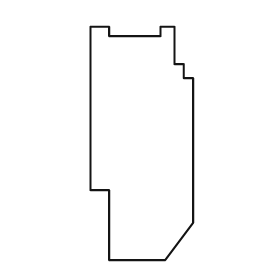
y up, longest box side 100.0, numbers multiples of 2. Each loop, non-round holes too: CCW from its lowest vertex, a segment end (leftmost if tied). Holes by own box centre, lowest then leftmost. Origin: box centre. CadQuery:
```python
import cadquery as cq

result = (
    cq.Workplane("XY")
    .moveTo(-14.0, -50.0)
    .lineTo(10.0, -50.0)
    .lineTo(22.0, -34.0)
    .lineTo(22.0, 28.0)
    .lineTo(18.0, 28.0)
    .lineTo(18.0, 34.0)
    .lineTo(14.0, 34.0)
    .lineTo(14.0, 50.0)
    .lineTo(8.0, 50.0)
    .lineTo(8.0, 46.0)
    .lineTo(-14.0, 46.0)
    .lineTo(-14.0, 50.0)
    .lineTo(-22.0, 50.0)
    .lineTo(-22.0, -20.0)
    .lineTo(-14.0, -20.0)
    .close()
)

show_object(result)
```